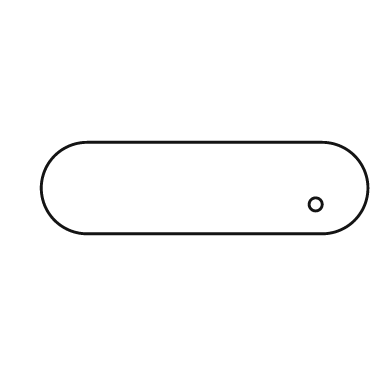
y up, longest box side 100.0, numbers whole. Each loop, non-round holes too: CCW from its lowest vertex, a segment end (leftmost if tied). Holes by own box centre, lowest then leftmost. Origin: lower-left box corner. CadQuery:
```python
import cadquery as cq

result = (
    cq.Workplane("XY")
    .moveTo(14.0, 0.0)
    .lineTo(86.0, 0.0)
    .threePointArc((100.0, 14.0), (86.0, 28.0))
    .lineTo(14.0, 28.0)
    .threePointArc((0.0, 14.0), (14.0, 0.0))
    .close()
    .moveTo(84.0, 9.0)
    .circle(2.0)
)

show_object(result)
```